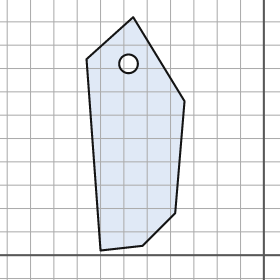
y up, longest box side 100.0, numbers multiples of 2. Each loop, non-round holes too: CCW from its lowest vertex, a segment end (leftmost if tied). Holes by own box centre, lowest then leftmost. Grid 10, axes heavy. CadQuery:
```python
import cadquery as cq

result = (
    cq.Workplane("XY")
    .moveTo(-70.0, 2.0)
    .lineTo(-52.0, 4.0)
    .lineTo(-38.0, 18.0)
    .lineTo(-34.0, 66.0)
    .lineTo(-56.0, 102.0)
    .lineTo(-76.0, 84.0)
    .close()
    .moveTo(-58.0, 82.0)
    .circle(4.0)
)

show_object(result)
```